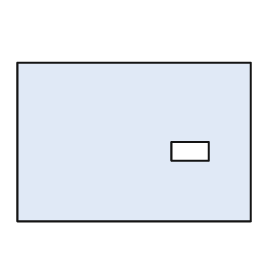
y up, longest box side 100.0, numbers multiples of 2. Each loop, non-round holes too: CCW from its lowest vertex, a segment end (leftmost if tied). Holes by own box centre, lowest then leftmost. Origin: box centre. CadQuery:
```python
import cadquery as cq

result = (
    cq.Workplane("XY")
    .moveTo(-50.0, -34.0)
    .lineTo(50.0, -34.0)
    .lineTo(50.0, 34.0)
    .lineTo(-50.0, 34.0)
    .close()
    .moveTo(16.0, -8.0)
    .lineTo(32.0, -8.0)
    .lineTo(32.0, 0.0)
    .lineTo(16.0, 0.0)
    .close()
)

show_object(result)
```